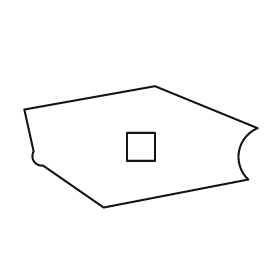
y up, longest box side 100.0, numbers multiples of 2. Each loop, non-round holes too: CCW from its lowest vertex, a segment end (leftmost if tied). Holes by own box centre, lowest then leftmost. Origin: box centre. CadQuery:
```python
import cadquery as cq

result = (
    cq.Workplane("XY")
    .moveTo(-16.0, -26.0)
    .lineTo(46.0, -14.0)
    .threePointArc((42.0, -2.0), (50.0, 8.0))
    .lineTo(6.0, 26.0)
    .lineTo(-50.0, 16.0)
    .lineTo(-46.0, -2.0)
    .threePointArc((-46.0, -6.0), (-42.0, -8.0))
    .close()
    .moveTo(-6.0, -6.0)
    .lineTo(6.0, -6.0)
    .lineTo(6.0, 6.0)
    .lineTo(-6.0, 6.0)
    .close()
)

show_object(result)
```